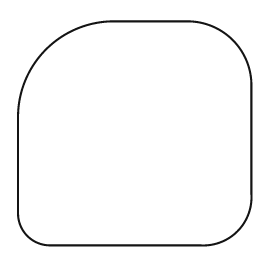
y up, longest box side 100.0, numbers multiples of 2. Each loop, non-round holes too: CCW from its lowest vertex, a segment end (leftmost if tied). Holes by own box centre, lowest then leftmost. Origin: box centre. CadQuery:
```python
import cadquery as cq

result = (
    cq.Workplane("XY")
    .moveTo(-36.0, -48.0)
    .lineTo(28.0, -48.0)
    .threePointArc((44.0, -42.0), (50.0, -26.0))
    .lineTo(50.0, 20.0)
    .threePointArc((42.0, 40.0), (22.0, 48.0))
    .lineTo(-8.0, 48.0)
    .threePointArc((-38.0, 36.0), (-50.0, 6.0))
    .lineTo(-50.0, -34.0)
    .threePointArc((-46.0, -44.0), (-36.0, -48.0))
    .close()
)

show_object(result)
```